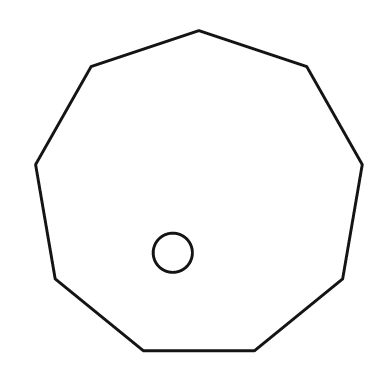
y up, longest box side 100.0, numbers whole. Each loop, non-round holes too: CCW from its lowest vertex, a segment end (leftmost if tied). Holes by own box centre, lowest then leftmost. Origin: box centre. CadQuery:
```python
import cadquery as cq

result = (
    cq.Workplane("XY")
    .moveTo(-17.0, -49.0)
    .lineTo(17.0, -49.0)
    .lineTo(44.0, -27.0)
    .lineTo(50.0, 8.0)
    .lineTo(33.0, 38.0)
    .lineTo(0.0, 49.0)
    .lineTo(-33.0, 38.0)
    .lineTo(-50.0, 8.0)
    .lineTo(-44.0, -27.0)
    .close()
    .moveTo(-8.0, -19.0)
    .circle(6.0)
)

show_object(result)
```